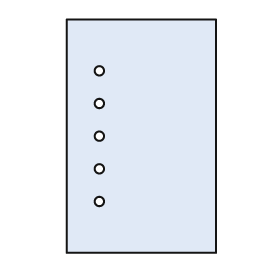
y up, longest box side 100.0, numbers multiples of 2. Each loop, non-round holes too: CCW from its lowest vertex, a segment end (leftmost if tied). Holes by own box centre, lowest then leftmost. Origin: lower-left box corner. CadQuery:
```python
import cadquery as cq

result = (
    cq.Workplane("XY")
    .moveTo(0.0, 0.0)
    .lineTo(64.0, 0.0)
    .lineTo(64.0, 100.0)
    .lineTo(0.0, 100.0)
    .close()
    .moveTo(14.0, 22.0)
    .circle(2.0)
    .moveTo(14.0, 36.0)
    .circle(2.0)
    .moveTo(14.0, 50.0)
    .circle(2.0)
    .moveTo(14.0, 64.0)
    .circle(2.0)
    .moveTo(14.0, 78.0)
    .circle(2.0)
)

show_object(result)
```